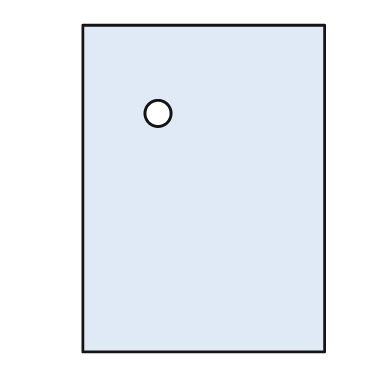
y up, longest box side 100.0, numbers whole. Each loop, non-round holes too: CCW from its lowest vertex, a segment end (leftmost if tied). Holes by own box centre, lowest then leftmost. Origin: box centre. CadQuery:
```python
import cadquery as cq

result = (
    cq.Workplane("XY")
    .moveTo(-37.0, -50.0)
    .lineTo(37.0, -50.0)
    .lineTo(37.0, 50.0)
    .lineTo(-37.0, 50.0)
    .close()
    .moveTo(-14.0, 23.0)
    .circle(4.0)
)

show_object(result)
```